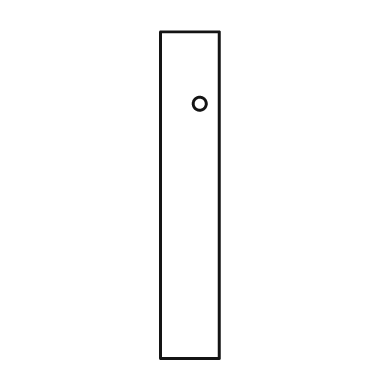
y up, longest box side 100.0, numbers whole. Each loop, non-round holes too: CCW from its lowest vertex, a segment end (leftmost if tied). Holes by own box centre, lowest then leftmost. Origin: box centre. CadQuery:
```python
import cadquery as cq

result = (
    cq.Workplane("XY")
    .moveTo(-9.0, -50.0)
    .lineTo(9.0, -50.0)
    .lineTo(9.0, 50.0)
    .lineTo(-9.0, 50.0)
    .close()
    .moveTo(3.0, 28.0)
    .circle(2.0)
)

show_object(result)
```